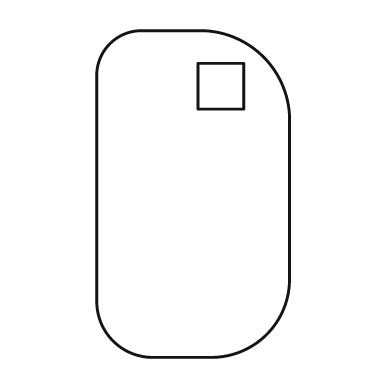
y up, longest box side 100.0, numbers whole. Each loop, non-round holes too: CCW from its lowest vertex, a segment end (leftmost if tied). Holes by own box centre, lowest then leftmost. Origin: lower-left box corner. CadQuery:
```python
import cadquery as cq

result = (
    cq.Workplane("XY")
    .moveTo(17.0, 0.0)
    .lineTo(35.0, 0.0)
    .threePointArc((52.0, 7.0), (59.0, 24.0))
    .lineTo(59.0, 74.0)
    .threePointArc((51.0, 92.0), (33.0, 100.0))
    .lineTo(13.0, 100.0)
    .threePointArc((4.0, 96.0), (0.0, 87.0))
    .lineTo(0.0, 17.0)
    .threePointArc((5.0, 5.0), (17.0, 0.0))
    .close()
    .moveTo(31.0, 76.0)
    .lineTo(45.0, 76.0)
    .lineTo(45.0, 90.0)
    .lineTo(31.0, 90.0)
    .close()
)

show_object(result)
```